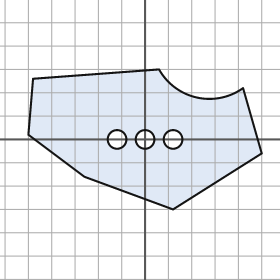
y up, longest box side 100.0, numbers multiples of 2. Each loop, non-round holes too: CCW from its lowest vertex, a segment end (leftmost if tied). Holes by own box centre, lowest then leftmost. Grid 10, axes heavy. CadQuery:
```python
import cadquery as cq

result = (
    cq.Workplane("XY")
    .moveTo(12.0, -30.0)
    .lineTo(50.0, -6.0)
    .lineTo(42.0, 22.0)
    .threePointArc((22.0, 18.0), (6.0, 30.0))
    .lineTo(-48.0, 26.0)
    .lineTo(-50.0, 2.0)
    .lineTo(-26.0, -16.0)
    .close()
    .moveTo(-12.0, 0.0)
    .circle(4.0)
    .moveTo(0.0, 0.0)
    .circle(4.0)
    .moveTo(12.0, 0.0)
    .circle(4.0)
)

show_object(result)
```